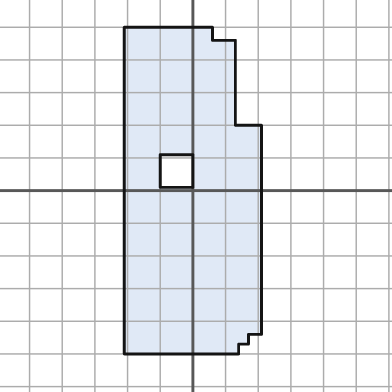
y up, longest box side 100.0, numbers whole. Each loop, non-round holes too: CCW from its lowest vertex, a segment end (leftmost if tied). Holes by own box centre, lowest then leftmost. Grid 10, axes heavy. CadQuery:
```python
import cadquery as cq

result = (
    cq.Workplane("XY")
    .moveTo(-21.0, -50.0)
    .lineTo(14.0, -50.0)
    .lineTo(14.0, -47.0)
    .lineTo(17.0, -47.0)
    .lineTo(17.0, -44.0)
    .lineTo(21.0, -44.0)
    .lineTo(21.0, 20.0)
    .lineTo(13.0, 20.0)
    .lineTo(13.0, 46.0)
    .lineTo(6.0, 46.0)
    .lineTo(6.0, 50.0)
    .lineTo(-21.0, 50.0)
    .close()
    .moveTo(-10.0, 1.0)
    .lineTo(0.0, 1.0)
    .lineTo(0.0, 11.0)
    .lineTo(-10.0, 11.0)
    .close()
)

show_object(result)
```